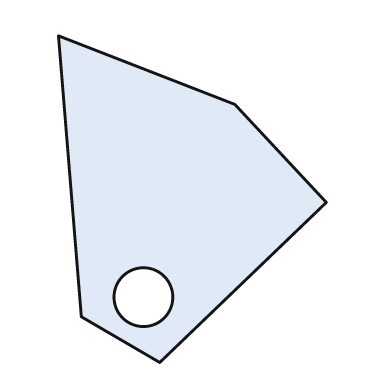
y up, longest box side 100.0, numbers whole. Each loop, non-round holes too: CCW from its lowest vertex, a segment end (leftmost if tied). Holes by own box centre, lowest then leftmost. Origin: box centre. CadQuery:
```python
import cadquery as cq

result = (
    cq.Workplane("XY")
    .moveTo(-10.0, -50.0)
    .lineTo(41.0, -1.0)
    .lineTo(13.0, 29.0)
    .lineTo(-41.0, 50.0)
    .lineTo(-34.0, -36.0)
    .close()
    .moveTo(-15.0, -30.0)
    .circle(9.0)
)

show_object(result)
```